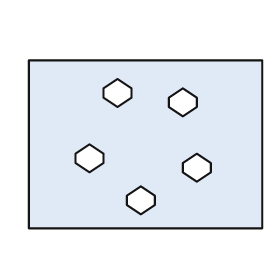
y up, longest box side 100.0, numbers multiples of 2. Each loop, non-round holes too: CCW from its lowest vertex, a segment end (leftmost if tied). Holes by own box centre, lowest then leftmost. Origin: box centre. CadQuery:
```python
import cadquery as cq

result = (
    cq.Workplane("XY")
    .moveTo(-50.0, -36.0)
    .lineTo(50.0, -36.0)
    .lineTo(50.0, 36.0)
    .lineTo(-50.0, 36.0)
    .close()
    .moveTo(-2.0, -30.0)
    .lineTo(4.0, -26.0)
    .lineTo(4.0, -22.0)
    .lineTo(-2.0, -18.0)
    .lineTo(-8.0, -22.0)
    .lineTo(-8.0, -26.0)
    .close()
    .moveTo(22.0, -16.0)
    .lineTo(28.0, -12.0)
    .lineTo(28.0, -8.0)
    .lineTo(22.0, -4.0)
    .lineTo(16.0, -8.0)
    .lineTo(16.0, -12.0)
    .close()
    .moveTo(-24.0, -12.0)
    .lineTo(-18.0, -8.0)
    .lineTo(-18.0, -4.0)
    .lineTo(-24.0, 0.0)
    .lineTo(-30.0, -4.0)
    .lineTo(-30.0, -8.0)
    .close()
    .moveTo(16.0, 12.0)
    .lineTo(22.0, 16.0)
    .lineTo(22.0, 20.0)
    .lineTo(16.0, 24.0)
    .lineTo(10.0, 20.0)
    .lineTo(10.0, 16.0)
    .close()
    .moveTo(-12.0, 16.0)
    .lineTo(-6.0, 20.0)
    .lineTo(-6.0, 24.0)
    .lineTo(-12.0, 28.0)
    .lineTo(-18.0, 24.0)
    .lineTo(-18.0, 20.0)
    .close()
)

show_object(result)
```